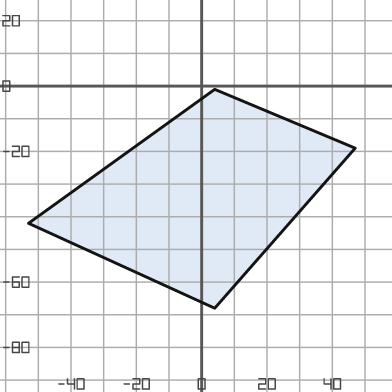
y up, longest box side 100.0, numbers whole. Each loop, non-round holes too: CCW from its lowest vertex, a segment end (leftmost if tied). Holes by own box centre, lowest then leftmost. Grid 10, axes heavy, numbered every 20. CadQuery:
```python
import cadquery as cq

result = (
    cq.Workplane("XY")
    .moveTo(4.0, -68.0)
    .lineTo(47.0, -19.0)
    .lineTo(4.0, -1.0)
    .lineTo(-53.0, -42.0)
    .close()
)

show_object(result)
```